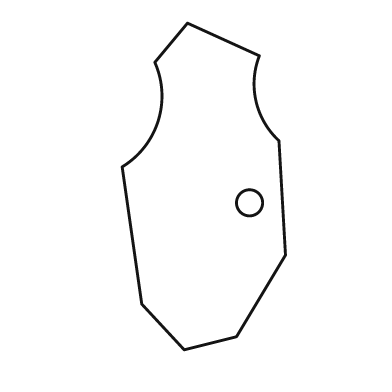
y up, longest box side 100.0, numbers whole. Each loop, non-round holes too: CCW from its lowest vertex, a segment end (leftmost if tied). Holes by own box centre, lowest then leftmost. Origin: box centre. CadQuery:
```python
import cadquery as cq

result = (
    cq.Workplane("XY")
    .moveTo(-6.0, -50.0)
    .lineTo(10.0, -46.0)
    .lineTo(25.0, -21.0)
    .lineTo(23.0, 14.0)
    .threePointArc((16.0, 26.0), (17.0, 40.0))
    .lineTo(-5.0, 50.0)
    .lineTo(-15.0, 38.0)
    .threePointArc((-14.0, 20.0), (-25.0, 6.0))
    .lineTo(-19.0, -36.0)
    .close()
    .moveTo(14.0, -5.0)
    .circle(4.0)
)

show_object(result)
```